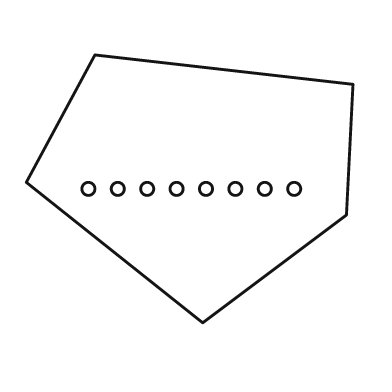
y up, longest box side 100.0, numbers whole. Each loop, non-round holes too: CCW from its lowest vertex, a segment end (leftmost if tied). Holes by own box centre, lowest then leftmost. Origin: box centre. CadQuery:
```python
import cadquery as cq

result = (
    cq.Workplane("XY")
    .moveTo(4.0, -41.0)
    .lineTo(48.0, -8.0)
    .lineTo(50.0, 32.0)
    .lineTo(-29.0, 41.0)
    .lineTo(-50.0, 2.0)
    .close()
    .moveTo(-31.0, 0.0)
    .circle(2.0)
    .moveTo(-22.0, 0.0)
    .circle(2.0)
    .moveTo(-13.0, 0.0)
    .circle(2.0)
    .moveTo(-4.0, 0.0)
    .circle(2.0)
    .moveTo(5.0, 0.0)
    .circle(2.0)
    .moveTo(14.0, 0.0)
    .circle(2.0)
    .moveTo(23.0, 0.0)
    .circle(2.0)
    .moveTo(32.0, 0.0)
    .circle(2.0)
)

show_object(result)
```